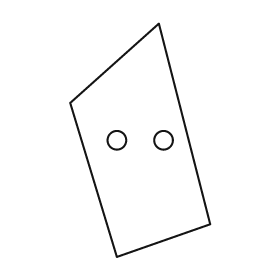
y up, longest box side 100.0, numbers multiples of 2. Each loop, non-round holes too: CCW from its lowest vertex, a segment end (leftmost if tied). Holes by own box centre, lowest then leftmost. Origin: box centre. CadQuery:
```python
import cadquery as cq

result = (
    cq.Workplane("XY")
    .moveTo(-10.0, -50.0)
    .lineTo(30.0, -36.0)
    .lineTo(8.0, 50.0)
    .lineTo(-30.0, 16.0)
    .close()
    .moveTo(-10.0, 0.0)
    .circle(4.0)
    .moveTo(10.0, 0.0)
    .circle(4.0)
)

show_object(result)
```